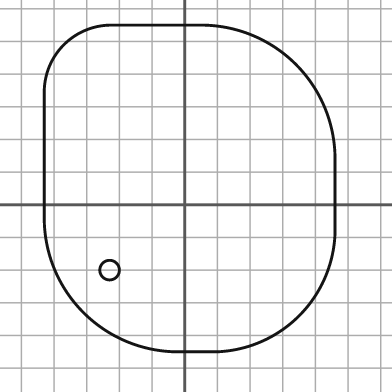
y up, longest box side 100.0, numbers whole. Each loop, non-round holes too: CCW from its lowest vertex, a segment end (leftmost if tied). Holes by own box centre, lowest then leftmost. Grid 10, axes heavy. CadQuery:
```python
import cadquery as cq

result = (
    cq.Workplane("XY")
    .moveTo(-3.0, -45.0)
    .lineTo(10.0, -45.0)
    .threePointArc((35.0, -34.0), (46.0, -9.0))
    .lineTo(46.0, 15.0)
    .threePointArc((34.0, 43.0), (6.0, 55.0))
    .lineTo(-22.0, 55.0)
    .threePointArc((-37.0, 49.0), (-43.0, 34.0))
    .lineTo(-43.0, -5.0)
    .threePointArc((-31.0, -33.0), (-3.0, -45.0))
    .close()
    .moveTo(-23.0, -20.0)
    .circle(3.0)
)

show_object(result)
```